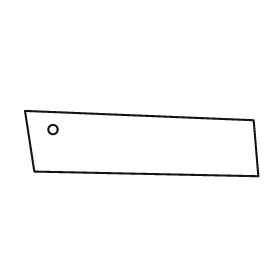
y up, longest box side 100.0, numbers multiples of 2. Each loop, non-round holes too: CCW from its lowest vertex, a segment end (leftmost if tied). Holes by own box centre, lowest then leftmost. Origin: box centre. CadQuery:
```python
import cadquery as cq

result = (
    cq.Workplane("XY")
    .moveTo(50.0, -14.0)
    .lineTo(48.0, 10.0)
    .lineTo(-50.0, 14.0)
    .lineTo(-46.0, -12.0)
    .close()
    .moveTo(-38.0, 6.0)
    .circle(2.0)
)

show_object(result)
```